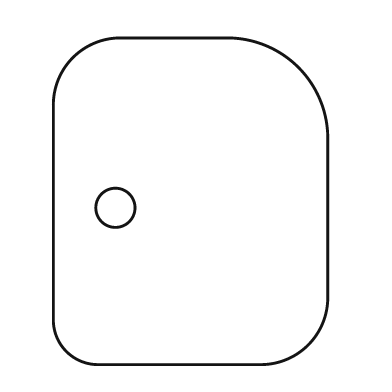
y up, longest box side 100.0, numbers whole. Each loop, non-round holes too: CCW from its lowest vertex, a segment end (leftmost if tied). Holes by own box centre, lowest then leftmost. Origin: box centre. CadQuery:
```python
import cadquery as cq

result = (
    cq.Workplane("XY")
    .moveTo(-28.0, -50.0)
    .lineTo(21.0, -50.0)
    .threePointArc((36.0, -44.0), (42.0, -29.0))
    .lineTo(42.0, 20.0)
    .threePointArc((33.0, 41.0), (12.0, 50.0))
    .lineTo(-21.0, 50.0)
    .threePointArc((-36.0, 44.0), (-42.0, 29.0))
    .lineTo(-42.0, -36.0)
    .threePointArc((-38.0, -46.0), (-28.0, -50.0))
    .close()
    .moveTo(-23.0, -2.0)
    .circle(6.0)
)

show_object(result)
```